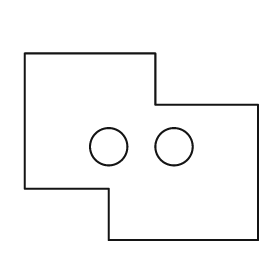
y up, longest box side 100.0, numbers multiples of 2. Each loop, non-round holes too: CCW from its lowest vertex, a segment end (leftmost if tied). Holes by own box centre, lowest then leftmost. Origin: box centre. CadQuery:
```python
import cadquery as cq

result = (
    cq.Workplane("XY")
    .moveTo(-14.0, -40.0)
    .lineTo(50.0, -40.0)
    .lineTo(50.0, 18.0)
    .lineTo(6.0, 18.0)
    .lineTo(6.0, 40.0)
    .lineTo(-50.0, 40.0)
    .lineTo(-50.0, -18.0)
    .lineTo(-14.0, -18.0)
    .close()
    .moveTo(-14.0, 0.0)
    .circle(8.0)
    .moveTo(14.0, 0.0)
    .circle(8.0)
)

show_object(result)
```